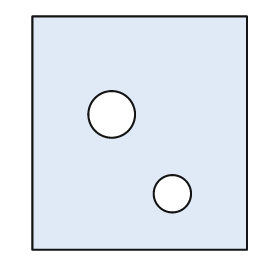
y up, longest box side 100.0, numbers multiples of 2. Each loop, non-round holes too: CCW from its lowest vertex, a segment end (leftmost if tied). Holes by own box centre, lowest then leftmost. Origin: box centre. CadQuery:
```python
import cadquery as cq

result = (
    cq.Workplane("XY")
    .moveTo(-46.0, -50.0)
    .lineTo(46.0, -50.0)
    .lineTo(46.0, 50.0)
    .lineTo(-46.0, 50.0)
    .close()
    .moveTo(14.0, -26.0)
    .circle(8.0)
    .moveTo(-12.0, 8.0)
    .circle(10.0)
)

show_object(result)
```